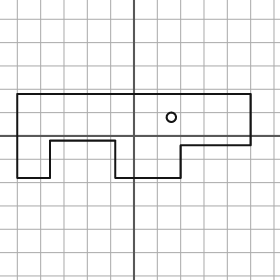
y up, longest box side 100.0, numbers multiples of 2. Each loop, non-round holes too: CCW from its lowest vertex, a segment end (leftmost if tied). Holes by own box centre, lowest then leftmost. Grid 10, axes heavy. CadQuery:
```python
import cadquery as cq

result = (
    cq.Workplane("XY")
    .moveTo(-50.0, -18.0)
    .lineTo(-36.0, -18.0)
    .lineTo(-36.0, -2.0)
    .lineTo(-8.0, -2.0)
    .lineTo(-8.0, -18.0)
    .lineTo(20.0, -18.0)
    .lineTo(20.0, -4.0)
    .lineTo(50.0, -4.0)
    .lineTo(50.0, 18.0)
    .lineTo(-50.0, 18.0)
    .close()
    .moveTo(16.0, 8.0)
    .circle(2.0)
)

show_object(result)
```